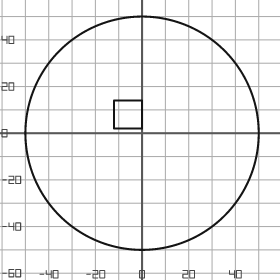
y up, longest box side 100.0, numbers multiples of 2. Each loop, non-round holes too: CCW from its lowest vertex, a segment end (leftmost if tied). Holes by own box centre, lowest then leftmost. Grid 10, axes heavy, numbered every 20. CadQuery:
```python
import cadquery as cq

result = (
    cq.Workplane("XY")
    .moveTo(0.0, 0.0)
    .circle(50.0)
    .moveTo(-12.0, 2.0)
    .lineTo(0.0, 2.0)
    .lineTo(0.0, 14.0)
    .lineTo(-12.0, 14.0)
    .close()
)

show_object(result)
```